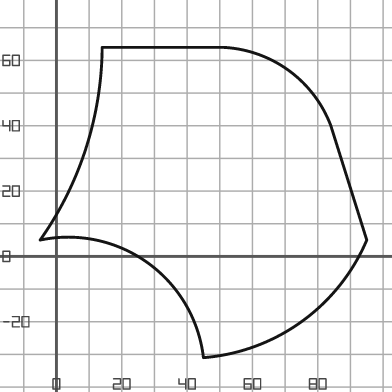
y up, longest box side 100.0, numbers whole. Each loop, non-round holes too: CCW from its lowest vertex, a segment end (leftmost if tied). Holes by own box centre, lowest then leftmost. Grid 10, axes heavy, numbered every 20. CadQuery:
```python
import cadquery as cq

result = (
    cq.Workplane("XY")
    .moveTo(45.0, -31.0)
    .threePointArc((75.0, -20.0), (95.0, 5.0))
    .lineTo(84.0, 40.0)
    .threePointArc((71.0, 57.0), (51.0, 64.0))
    .lineTo(14.0, 64.0)
    .threePointArc((9.0, 33.0), (-5.0, 5.0))
    .threePointArc((28.0, -2.0), (45.0, -31.0))
    .close()
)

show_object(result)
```